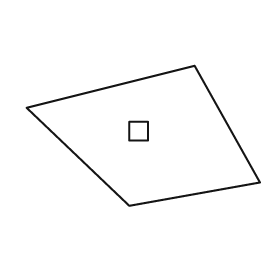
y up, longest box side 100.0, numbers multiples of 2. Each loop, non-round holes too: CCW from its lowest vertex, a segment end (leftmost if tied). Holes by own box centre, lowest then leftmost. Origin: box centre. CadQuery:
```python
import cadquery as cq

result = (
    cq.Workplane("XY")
    .moveTo(-6.0, -30.0)
    .lineTo(50.0, -20.0)
    .lineTo(22.0, 30.0)
    .lineTo(-50.0, 12.0)
    .close()
    .moveTo(-6.0, -2.0)
    .lineTo(2.0, -2.0)
    .lineTo(2.0, 6.0)
    .lineTo(-6.0, 6.0)
    .close()
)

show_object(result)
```